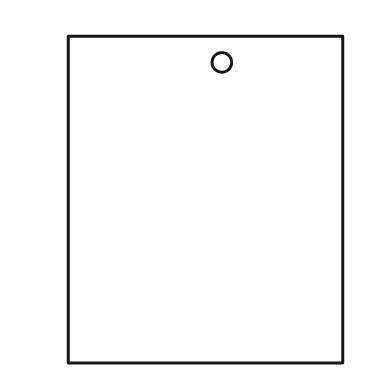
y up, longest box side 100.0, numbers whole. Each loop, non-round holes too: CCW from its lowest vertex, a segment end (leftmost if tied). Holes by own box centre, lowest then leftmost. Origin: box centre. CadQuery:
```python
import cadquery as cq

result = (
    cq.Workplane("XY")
    .moveTo(-42.0, -50.0)
    .lineTo(42.0, -50.0)
    .lineTo(42.0, 50.0)
    .lineTo(-42.0, 50.0)
    .close()
    .moveTo(5.0, 42.0)
    .circle(3.0)
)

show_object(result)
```